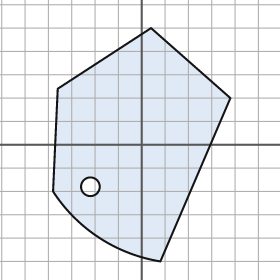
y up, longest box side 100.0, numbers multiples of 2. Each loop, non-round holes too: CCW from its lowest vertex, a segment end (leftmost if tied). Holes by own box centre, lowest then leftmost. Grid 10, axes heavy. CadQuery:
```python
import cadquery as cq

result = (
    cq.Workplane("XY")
    .moveTo(8.0, -50.0)
    .lineTo(38.0, 20.0)
    .lineTo(4.0, 50.0)
    .lineTo(-36.0, 24.0)
    .lineTo(-38.0, -20.0)
    .threePointArc((-18.0, -40.0), (8.0, -50.0))
    .close()
    .moveTo(-22.0, -18.0)
    .circle(4.0)
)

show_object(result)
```